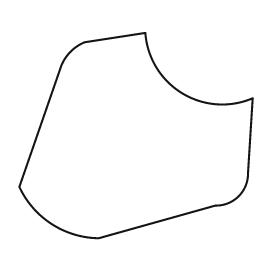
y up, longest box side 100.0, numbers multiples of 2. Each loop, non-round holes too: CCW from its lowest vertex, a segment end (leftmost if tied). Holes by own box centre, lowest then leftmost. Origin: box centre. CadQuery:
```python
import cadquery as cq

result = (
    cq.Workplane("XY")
    .moveTo(-16.0, -44.0)
    .lineTo(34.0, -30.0)
    .threePointArc((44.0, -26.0), (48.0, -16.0))
    .lineTo(50.0, 16.0)
    .threePointArc((20.0, 18.0), (4.0, 44.0))
    .lineTo(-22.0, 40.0)
    .threePointArc((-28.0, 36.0), (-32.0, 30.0))
    .lineTo(-50.0, -22.0)
    .threePointArc((-36.0, -38.0), (-16.0, -44.0))
    .close()
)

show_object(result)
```